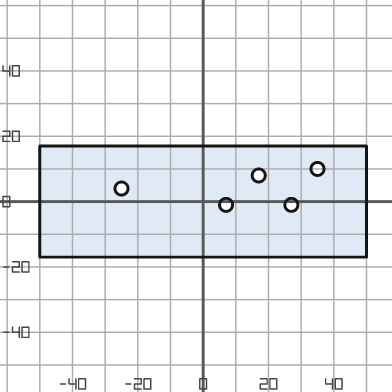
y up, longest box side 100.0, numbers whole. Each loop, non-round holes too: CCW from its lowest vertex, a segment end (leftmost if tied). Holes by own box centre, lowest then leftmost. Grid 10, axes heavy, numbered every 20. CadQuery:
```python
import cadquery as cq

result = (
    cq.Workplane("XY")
    .moveTo(-50.0, -17.0)
    .lineTo(50.0, -17.0)
    .lineTo(50.0, 17.0)
    .lineTo(-50.0, 17.0)
    .close()
    .moveTo(7.0, -1.0)
    .circle(2.0)
    .moveTo(27.0, -1.0)
    .circle(2.0)
    .moveTo(-25.0, 4.0)
    .circle(2.0)
    .moveTo(17.0, 8.0)
    .circle(2.0)
    .moveTo(35.0, 10.0)
    .circle(2.0)
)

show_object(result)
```